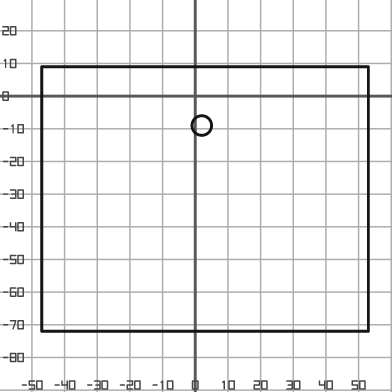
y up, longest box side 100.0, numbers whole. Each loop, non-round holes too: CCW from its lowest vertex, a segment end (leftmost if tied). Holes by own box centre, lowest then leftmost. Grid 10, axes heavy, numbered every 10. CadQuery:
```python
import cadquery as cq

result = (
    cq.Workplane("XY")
    .moveTo(-47.0, -72.0)
    .lineTo(53.0, -72.0)
    .lineTo(53.0, 9.0)
    .lineTo(-47.0, 9.0)
    .close()
    .moveTo(2.0, -9.0)
    .circle(3.0)
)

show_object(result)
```